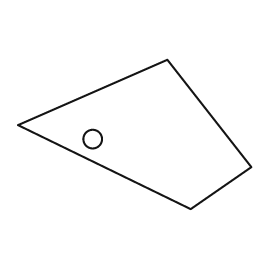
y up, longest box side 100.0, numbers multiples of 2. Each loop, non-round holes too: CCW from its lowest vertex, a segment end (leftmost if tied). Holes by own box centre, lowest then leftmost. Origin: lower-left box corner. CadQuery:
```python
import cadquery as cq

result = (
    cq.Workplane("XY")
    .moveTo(74.0, 0.0)
    .lineTo(100.0, 18.0)
    .lineTo(64.0, 64.0)
    .lineTo(0.0, 36.0)
    .close()
    .moveTo(32.0, 30.0)
    .circle(4.0)
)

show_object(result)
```